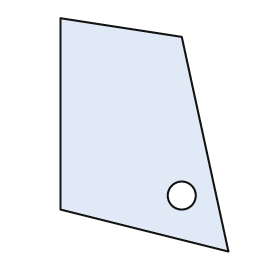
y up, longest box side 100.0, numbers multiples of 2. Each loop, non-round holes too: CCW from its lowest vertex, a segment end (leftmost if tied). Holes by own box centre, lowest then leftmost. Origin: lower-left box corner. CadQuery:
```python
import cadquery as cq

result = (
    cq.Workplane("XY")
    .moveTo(72.0, 0.0)
    .lineTo(52.0, 92.0)
    .lineTo(0.0, 100.0)
    .lineTo(0.0, 18.0)
    .close()
    .moveTo(52.0, 24.0)
    .circle(6.0)
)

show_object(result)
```